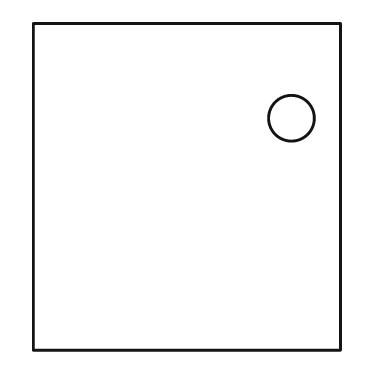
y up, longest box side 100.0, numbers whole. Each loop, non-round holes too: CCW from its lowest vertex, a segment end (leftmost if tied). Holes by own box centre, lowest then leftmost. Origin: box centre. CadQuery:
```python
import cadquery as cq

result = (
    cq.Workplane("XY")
    .moveTo(-47.0, -50.0)
    .lineTo(47.0, -50.0)
    .lineTo(47.0, 50.0)
    .lineTo(-47.0, 50.0)
    .close()
    .moveTo(32.0, 21.0)
    .circle(7.0)
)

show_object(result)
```